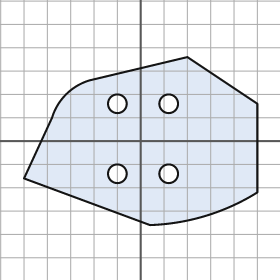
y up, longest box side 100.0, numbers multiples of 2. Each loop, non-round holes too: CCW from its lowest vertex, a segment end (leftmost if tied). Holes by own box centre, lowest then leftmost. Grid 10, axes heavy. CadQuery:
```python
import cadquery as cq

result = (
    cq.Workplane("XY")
    .moveTo(4.0, -36.0)
    .threePointArc((28.0, -32.0), (50.0, -22.0))
    .lineTo(50.0, 16.0)
    .lineTo(20.0, 36.0)
    .lineTo(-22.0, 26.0)
    .threePointArc((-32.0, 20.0), (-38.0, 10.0))
    .lineTo(-50.0, -16.0)
    .close()
    .moveTo(-10.0, -14.0)
    .circle(4.0)
    .moveTo(12.0, -14.0)
    .circle(4.0)
    .moveTo(-10.0, 16.0)
    .circle(4.0)
    .moveTo(12.0, 16.0)
    .circle(4.0)
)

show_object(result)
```